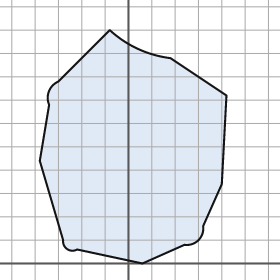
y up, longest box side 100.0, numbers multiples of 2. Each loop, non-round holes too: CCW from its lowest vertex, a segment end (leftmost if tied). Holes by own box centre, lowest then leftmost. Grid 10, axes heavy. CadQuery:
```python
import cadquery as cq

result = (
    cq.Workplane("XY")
    .moveTo(6.0, 0.0)
    .lineTo(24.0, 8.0)
    .threePointArc((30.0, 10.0), (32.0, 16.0))
    .lineTo(40.0, 34.0)
    .lineTo(42.0, 72.0)
    .lineTo(18.0, 88.0)
    .threePointArc((4.0, 92.0), (-8.0, 100.0))
    .lineTo(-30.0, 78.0)
    .threePointArc((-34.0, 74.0), (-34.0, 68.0))
    .lineTo(-38.0, 44.0)
    .lineTo(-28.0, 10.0)
    .threePointArc((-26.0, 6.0), (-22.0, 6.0))
    .close()
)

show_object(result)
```